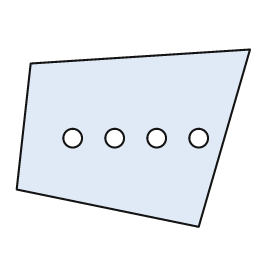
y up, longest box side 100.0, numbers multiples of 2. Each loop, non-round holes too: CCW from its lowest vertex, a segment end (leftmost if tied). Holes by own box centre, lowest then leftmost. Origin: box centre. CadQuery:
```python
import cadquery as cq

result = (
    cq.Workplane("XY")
    .moveTo(28.0, -38.0)
    .lineTo(50.0, 38.0)
    .lineTo(-44.0, 32.0)
    .lineTo(-50.0, -22.0)
    .close()
    .moveTo(-26.0, 0.0)
    .circle(4.0)
    .moveTo(-8.0, 0.0)
    .circle(4.0)
    .moveTo(10.0, 0.0)
    .circle(4.0)
    .moveTo(28.0, 0.0)
    .circle(4.0)
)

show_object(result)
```